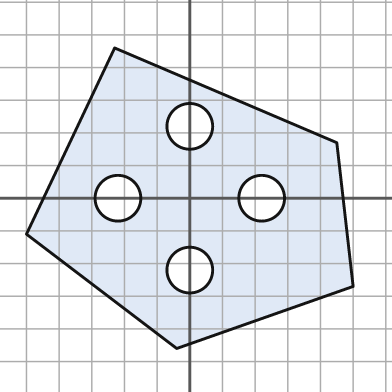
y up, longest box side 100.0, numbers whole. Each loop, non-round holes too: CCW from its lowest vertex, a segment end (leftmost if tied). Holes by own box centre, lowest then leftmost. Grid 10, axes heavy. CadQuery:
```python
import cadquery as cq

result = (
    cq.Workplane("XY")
    .moveTo(-4.0, -46.0)
    .lineTo(50.0, -27.0)
    .lineTo(45.0, 17.0)
    .lineTo(-23.0, 46.0)
    .lineTo(-50.0, -11.0)
    .close()
    .moveTo(0.0, -22.0)
    .circle(7.0)
    .moveTo(-22.0, 0.0)
    .circle(7.0)
    .moveTo(22.0, 0.0)
    .circle(7.0)
    .moveTo(0.0, 22.0)
    .circle(7.0)
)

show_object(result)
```